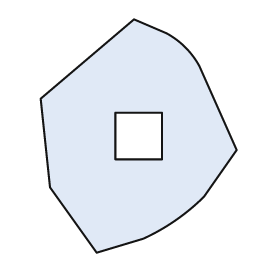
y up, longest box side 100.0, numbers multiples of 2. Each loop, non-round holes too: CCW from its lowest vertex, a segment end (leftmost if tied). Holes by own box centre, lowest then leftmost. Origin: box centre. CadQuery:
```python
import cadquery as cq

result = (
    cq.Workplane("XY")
    .moveTo(-18.0, -50.0)
    .lineTo(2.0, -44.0)
    .threePointArc((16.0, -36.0), (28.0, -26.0))
    .lineTo(42.0, -6.0)
    .lineTo(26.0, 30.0)
    .threePointArc((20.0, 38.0), (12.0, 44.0))
    .lineTo(-2.0, 50.0)
    .lineTo(-42.0, 16.0)
    .lineTo(-38.0, -22.0)
    .close()
    .moveTo(-10.0, -10.0)
    .lineTo(10.0, -10.0)
    .lineTo(10.0, 10.0)
    .lineTo(-10.0, 10.0)
    .close()
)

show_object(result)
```